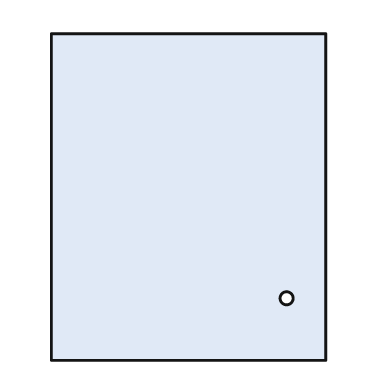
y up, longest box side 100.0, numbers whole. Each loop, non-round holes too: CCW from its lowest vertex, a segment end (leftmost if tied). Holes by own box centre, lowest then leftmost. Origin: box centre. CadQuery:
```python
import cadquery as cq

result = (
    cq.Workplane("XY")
    .moveTo(-42.0, -50.0)
    .lineTo(42.0, -50.0)
    .lineTo(42.0, 50.0)
    .lineTo(-42.0, 50.0)
    .close()
    .moveTo(30.0, -31.0)
    .circle(2.0)
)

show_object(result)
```